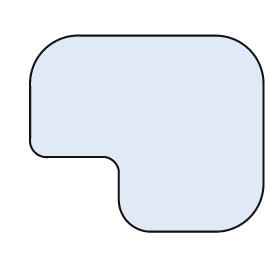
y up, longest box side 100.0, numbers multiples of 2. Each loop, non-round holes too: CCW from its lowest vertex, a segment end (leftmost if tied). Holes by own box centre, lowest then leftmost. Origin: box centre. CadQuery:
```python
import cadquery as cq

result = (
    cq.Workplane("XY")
    .moveTo(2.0, -42.0)
    .lineTo(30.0, -42.0)
    .threePointArc((44.0, -36.0), (50.0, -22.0))
    .lineTo(50.0, 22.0)
    .threePointArc((44.0, 36.0), (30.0, 42.0))
    .lineTo(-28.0, 42.0)
    .threePointArc((-44.0, 36.0), (-50.0, 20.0))
    .lineTo(-50.0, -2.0)
    .threePointArc((-48.0, -8.0), (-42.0, -10.0))
    .lineTo(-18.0, -10.0)
    .threePointArc((-14.0, -12.0), (-12.0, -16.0))
    .lineTo(-12.0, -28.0)
    .threePointArc((-8.0, -38.0), (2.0, -42.0))
    .close()
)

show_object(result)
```